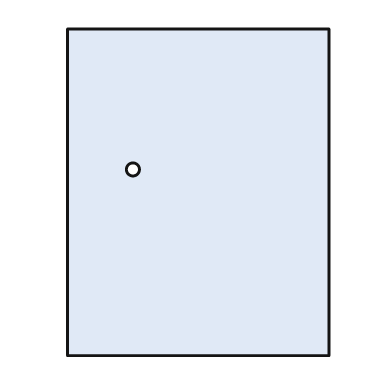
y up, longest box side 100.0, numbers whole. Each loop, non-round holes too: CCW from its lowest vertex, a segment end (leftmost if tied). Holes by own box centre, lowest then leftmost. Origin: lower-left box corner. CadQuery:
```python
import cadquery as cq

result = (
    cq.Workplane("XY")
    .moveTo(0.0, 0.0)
    .lineTo(80.0, 0.0)
    .lineTo(80.0, 100.0)
    .lineTo(0.0, 100.0)
    .close()
    .moveTo(20.0, 57.0)
    .circle(2.0)
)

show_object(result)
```